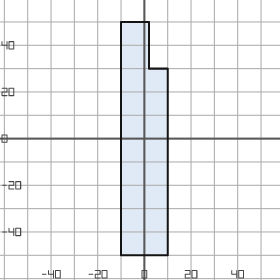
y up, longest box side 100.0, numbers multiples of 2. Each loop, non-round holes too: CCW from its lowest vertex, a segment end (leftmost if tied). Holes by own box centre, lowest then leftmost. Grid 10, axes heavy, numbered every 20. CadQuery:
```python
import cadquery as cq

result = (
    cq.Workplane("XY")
    .moveTo(-10.0, -50.0)
    .lineTo(10.0, -50.0)
    .lineTo(10.0, 30.0)
    .lineTo(2.0, 30.0)
    .lineTo(2.0, 50.0)
    .lineTo(-10.0, 50.0)
    .close()
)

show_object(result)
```